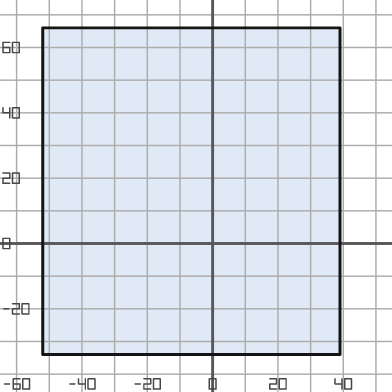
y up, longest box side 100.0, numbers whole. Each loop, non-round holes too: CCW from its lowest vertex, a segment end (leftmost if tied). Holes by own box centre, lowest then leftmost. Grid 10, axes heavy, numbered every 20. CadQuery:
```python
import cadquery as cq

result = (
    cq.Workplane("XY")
    .moveTo(-52.0, -34.0)
    .lineTo(39.0, -34.0)
    .lineTo(39.0, 66.0)
    .lineTo(-52.0, 66.0)
    .close()
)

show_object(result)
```